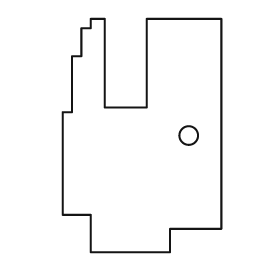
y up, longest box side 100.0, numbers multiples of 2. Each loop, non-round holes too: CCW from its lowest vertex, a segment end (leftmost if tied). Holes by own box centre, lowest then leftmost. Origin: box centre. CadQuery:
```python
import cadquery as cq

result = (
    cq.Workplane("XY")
    .moveTo(-22.0, -50.0)
    .lineTo(12.0, -50.0)
    .lineTo(12.0, -40.0)
    .lineTo(34.0, -40.0)
    .lineTo(34.0, 50.0)
    .lineTo(2.0, 50.0)
    .lineTo(2.0, 12.0)
    .lineTo(-16.0, 12.0)
    .lineTo(-16.0, 50.0)
    .lineTo(-22.0, 50.0)
    .lineTo(-22.0, 46.0)
    .lineTo(-26.0, 46.0)
    .lineTo(-26.0, 34.0)
    .lineTo(-30.0, 34.0)
    .lineTo(-30.0, 10.0)
    .lineTo(-34.0, 10.0)
    .lineTo(-34.0, -34.0)
    .lineTo(-22.0, -34.0)
    .close()
    .moveTo(20.0, 0.0)
    .circle(4.0)
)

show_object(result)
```